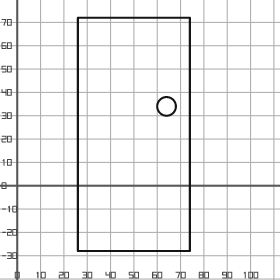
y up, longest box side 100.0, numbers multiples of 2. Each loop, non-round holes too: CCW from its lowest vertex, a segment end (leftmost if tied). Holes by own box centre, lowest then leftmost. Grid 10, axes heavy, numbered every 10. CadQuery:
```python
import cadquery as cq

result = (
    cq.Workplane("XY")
    .moveTo(26.0, -28.0)
    .lineTo(74.0, -28.0)
    .lineTo(74.0, 72.0)
    .lineTo(26.0, 72.0)
    .close()
    .moveTo(64.0, 34.0)
    .circle(4.0)
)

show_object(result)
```